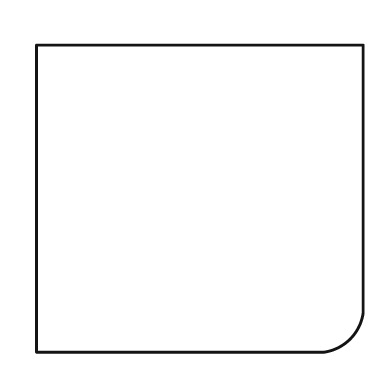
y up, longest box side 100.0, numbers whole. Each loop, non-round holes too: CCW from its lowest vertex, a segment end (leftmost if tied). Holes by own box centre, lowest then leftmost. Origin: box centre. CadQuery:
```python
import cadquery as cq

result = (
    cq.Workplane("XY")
    .moveTo(-50.0, -47.0)
    .lineTo(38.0, -47.0)
    .threePointArc((46.0, -43.0), (50.0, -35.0))
    .lineTo(50.0, 47.0)
    .lineTo(-50.0, 47.0)
    .close()
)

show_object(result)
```